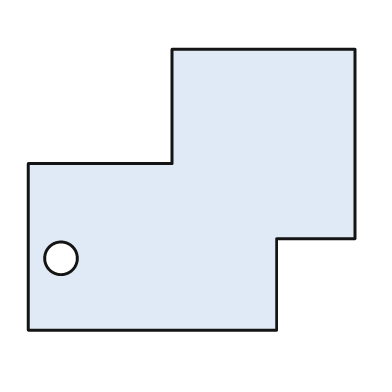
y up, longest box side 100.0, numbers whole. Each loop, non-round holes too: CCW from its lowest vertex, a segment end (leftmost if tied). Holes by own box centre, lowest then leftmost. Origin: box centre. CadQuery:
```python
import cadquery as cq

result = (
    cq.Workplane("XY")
    .moveTo(-50.0, -43.0)
    .lineTo(26.0, -43.0)
    .lineTo(26.0, -15.0)
    .lineTo(50.0, -15.0)
    .lineTo(50.0, 43.0)
    .lineTo(-6.0, 43.0)
    .lineTo(-6.0, 8.0)
    .lineTo(-50.0, 8.0)
    .close()
    .moveTo(-40.0, -21.0)
    .circle(5.0)
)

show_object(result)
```